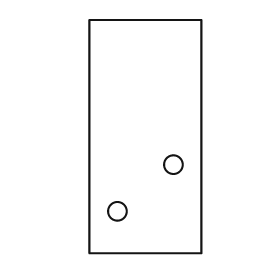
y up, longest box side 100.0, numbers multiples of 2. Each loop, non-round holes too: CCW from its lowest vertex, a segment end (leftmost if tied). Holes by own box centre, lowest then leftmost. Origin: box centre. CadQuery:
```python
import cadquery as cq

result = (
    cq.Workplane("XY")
    .moveTo(-24.0, -50.0)
    .lineTo(24.0, -50.0)
    .lineTo(24.0, 50.0)
    .lineTo(-24.0, 50.0)
    .close()
    .moveTo(-12.0, -32.0)
    .circle(4.0)
    .moveTo(12.0, -12.0)
    .circle(4.0)
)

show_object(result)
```